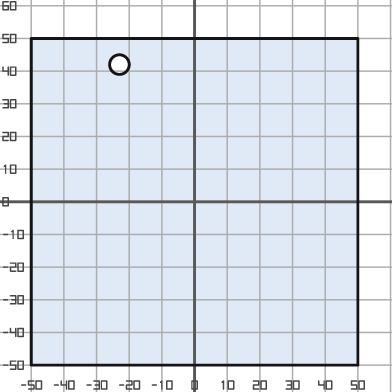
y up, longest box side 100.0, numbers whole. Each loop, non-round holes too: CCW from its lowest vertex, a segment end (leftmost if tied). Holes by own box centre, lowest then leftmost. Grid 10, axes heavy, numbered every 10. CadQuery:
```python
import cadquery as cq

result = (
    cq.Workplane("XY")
    .moveTo(-50.0, -50.0)
    .lineTo(50.0, -50.0)
    .lineTo(50.0, 50.0)
    .lineTo(-50.0, 50.0)
    .close()
    .moveTo(-23.0, 42.0)
    .circle(3.0)
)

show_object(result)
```